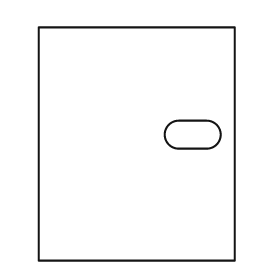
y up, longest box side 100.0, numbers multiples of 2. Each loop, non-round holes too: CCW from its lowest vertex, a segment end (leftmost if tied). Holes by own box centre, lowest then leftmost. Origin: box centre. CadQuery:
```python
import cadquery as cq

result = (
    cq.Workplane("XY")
    .moveTo(-42.0, -50.0)
    .lineTo(42.0, -50.0)
    .lineTo(42.0, 50.0)
    .lineTo(-42.0, 50.0)
    .close()
    .moveTo(18.0, -2.0)
    .lineTo(30.0, -2.0)
    .threePointArc((36.0, 4.0), (30.0, 10.0))
    .lineTo(18.0, 10.0)
    .threePointArc((12.0, 4.0), (18.0, -2.0))
    .close()
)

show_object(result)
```